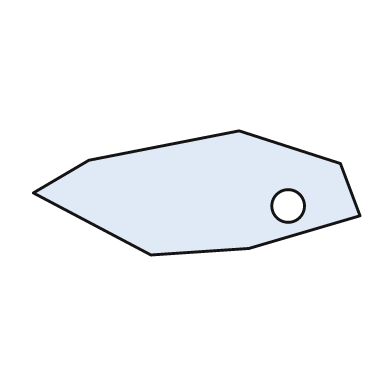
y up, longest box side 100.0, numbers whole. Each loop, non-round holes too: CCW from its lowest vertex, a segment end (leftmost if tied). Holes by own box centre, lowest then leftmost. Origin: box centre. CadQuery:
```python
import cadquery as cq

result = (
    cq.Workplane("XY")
    .moveTo(-14.0, -19.0)
    .lineTo(16.0, -17.0)
    .lineTo(50.0, -7.0)
    .lineTo(44.0, 9.0)
    .lineTo(13.0, 19.0)
    .lineTo(-33.0, 10.0)
    .lineTo(-50.0, 0.0)
    .close()
    .moveTo(28.0, -4.0)
    .circle(5.0)
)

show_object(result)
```